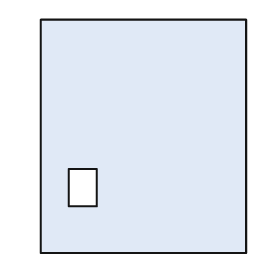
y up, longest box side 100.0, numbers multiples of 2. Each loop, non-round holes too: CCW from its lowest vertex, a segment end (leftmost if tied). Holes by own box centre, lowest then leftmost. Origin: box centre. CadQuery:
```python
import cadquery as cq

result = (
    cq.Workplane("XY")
    .moveTo(-44.0, -50.0)
    .lineTo(44.0, -50.0)
    .lineTo(44.0, 50.0)
    .lineTo(-44.0, 50.0)
    .close()
    .moveTo(-32.0, -30.0)
    .lineTo(-20.0, -30.0)
    .lineTo(-20.0, -14.0)
    .lineTo(-32.0, -14.0)
    .close()
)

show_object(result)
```